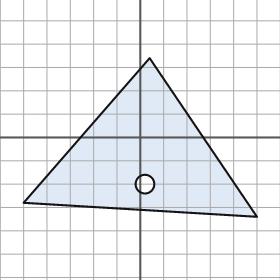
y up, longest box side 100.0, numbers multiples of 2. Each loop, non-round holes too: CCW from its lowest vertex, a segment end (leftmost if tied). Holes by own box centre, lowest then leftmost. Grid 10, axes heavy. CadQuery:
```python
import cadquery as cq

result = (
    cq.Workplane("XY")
    .moveTo(50.0, -34.0)
    .lineTo(4.0, 34.0)
    .lineTo(-50.0, -28.0)
    .close()
    .moveTo(2.0, -20.0)
    .circle(4.0)
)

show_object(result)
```